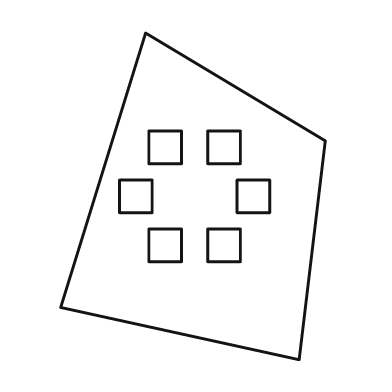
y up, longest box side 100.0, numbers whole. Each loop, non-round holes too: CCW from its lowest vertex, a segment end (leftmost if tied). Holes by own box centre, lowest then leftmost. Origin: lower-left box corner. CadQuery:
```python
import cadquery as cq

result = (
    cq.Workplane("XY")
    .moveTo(73.0, 0.0)
    .lineTo(81.0, 67.0)
    .lineTo(26.0, 100.0)
    .lineTo(0.0, 16.0)
    .close()
    .moveTo(27.0, 30.0)
    .lineTo(37.0, 30.0)
    .lineTo(37.0, 40.0)
    .lineTo(27.0, 40.0)
    .close()
    .moveTo(45.0, 30.0)
    .lineTo(55.0, 30.0)
    .lineTo(55.0, 40.0)
    .lineTo(45.0, 40.0)
    .close()
    .moveTo(18.0, 45.0)
    .lineTo(28.0, 45.0)
    .lineTo(28.0, 55.0)
    .lineTo(18.0, 55.0)
    .close()
    .moveTo(54.0, 45.0)
    .lineTo(64.0, 45.0)
    .lineTo(64.0, 55.0)
    .lineTo(54.0, 55.0)
    .close()
    .moveTo(27.0, 60.0)
    .lineTo(37.0, 60.0)
    .lineTo(37.0, 70.0)
    .lineTo(27.0, 70.0)
    .close()
    .moveTo(45.0, 60.0)
    .lineTo(55.0, 60.0)
    .lineTo(55.0, 70.0)
    .lineTo(45.0, 70.0)
    .close()
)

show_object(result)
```